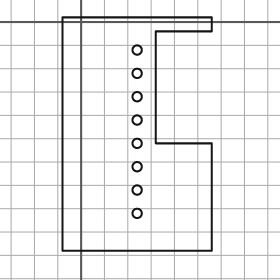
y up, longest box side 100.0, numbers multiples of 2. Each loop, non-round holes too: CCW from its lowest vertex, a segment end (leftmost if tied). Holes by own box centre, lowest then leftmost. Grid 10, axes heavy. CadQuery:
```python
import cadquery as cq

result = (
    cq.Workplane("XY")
    .moveTo(-8.0, -98.0)
    .lineTo(56.0, -98.0)
    .lineTo(56.0, -52.0)
    .lineTo(32.0, -52.0)
    .lineTo(32.0, -4.0)
    .lineTo(56.0, -4.0)
    .lineTo(56.0, 2.0)
    .lineTo(-8.0, 2.0)
    .close()
    .moveTo(24.0, -82.0)
    .circle(2.0)
    .moveTo(24.0, -72.0)
    .circle(2.0)
    .moveTo(24.0, -62.0)
    .circle(2.0)
    .moveTo(24.0, -52.0)
    .circle(2.0)
    .moveTo(24.0, -42.0)
    .circle(2.0)
    .moveTo(24.0, -32.0)
    .circle(2.0)
    .moveTo(24.0, -22.0)
    .circle(2.0)
    .moveTo(24.0, -12.0)
    .circle(2.0)
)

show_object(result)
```